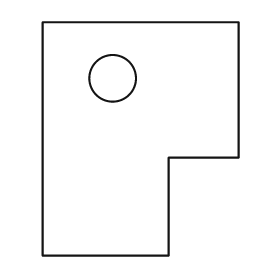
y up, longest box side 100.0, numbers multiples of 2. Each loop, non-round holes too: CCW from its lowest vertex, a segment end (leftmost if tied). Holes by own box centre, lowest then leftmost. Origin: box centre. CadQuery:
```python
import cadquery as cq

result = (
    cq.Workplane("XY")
    .moveTo(-42.0, -50.0)
    .lineTo(12.0, -50.0)
    .lineTo(12.0, -8.0)
    .lineTo(42.0, -8.0)
    .lineTo(42.0, 50.0)
    .lineTo(-42.0, 50.0)
    .close()
    .moveTo(-12.0, 26.0)
    .circle(10.0)
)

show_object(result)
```